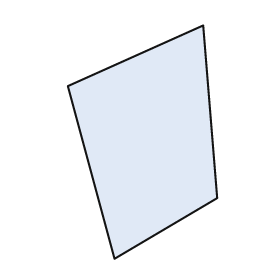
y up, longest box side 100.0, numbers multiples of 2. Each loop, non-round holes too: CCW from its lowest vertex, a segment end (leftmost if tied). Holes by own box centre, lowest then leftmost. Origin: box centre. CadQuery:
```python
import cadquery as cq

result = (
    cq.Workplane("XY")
    .moveTo(-12.0, -50.0)
    .lineTo(32.0, -24.0)
    .lineTo(26.0, 50.0)
    .lineTo(-32.0, 24.0)
    .close()
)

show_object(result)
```